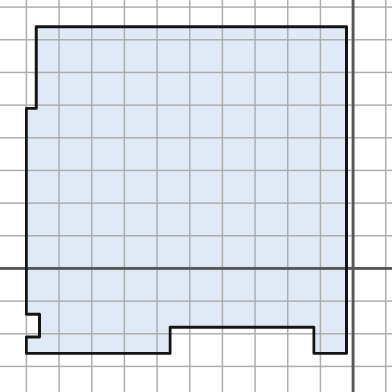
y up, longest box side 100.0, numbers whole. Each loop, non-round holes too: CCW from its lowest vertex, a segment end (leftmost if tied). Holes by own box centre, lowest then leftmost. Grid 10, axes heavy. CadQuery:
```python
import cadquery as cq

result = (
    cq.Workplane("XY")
    .moveTo(-100.0, -26.0)
    .lineTo(-56.0, -26.0)
    .lineTo(-56.0, -18.0)
    .lineTo(-12.0, -18.0)
    .lineTo(-12.0, -26.0)
    .lineTo(-2.0, -26.0)
    .lineTo(-2.0, 74.0)
    .lineTo(-97.0, 74.0)
    .lineTo(-97.0, 49.0)
    .lineTo(-100.0, 49.0)
    .lineTo(-100.0, -14.0)
    .lineTo(-96.0, -14.0)
    .lineTo(-96.0, -21.0)
    .lineTo(-100.0, -21.0)
    .close()
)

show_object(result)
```